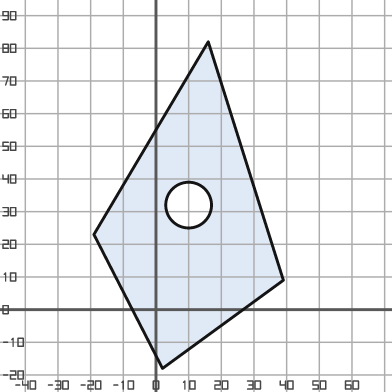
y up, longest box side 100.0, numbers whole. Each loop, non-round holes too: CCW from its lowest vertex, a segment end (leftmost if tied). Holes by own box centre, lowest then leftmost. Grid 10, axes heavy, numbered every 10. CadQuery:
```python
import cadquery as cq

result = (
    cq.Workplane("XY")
    .moveTo(2.0, -18.0)
    .lineTo(39.0, 9.0)
    .lineTo(16.0, 82.0)
    .lineTo(-19.0, 23.0)
    .close()
    .moveTo(10.0, 32.0)
    .circle(7.0)
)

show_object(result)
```